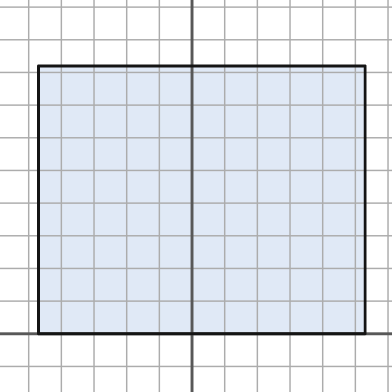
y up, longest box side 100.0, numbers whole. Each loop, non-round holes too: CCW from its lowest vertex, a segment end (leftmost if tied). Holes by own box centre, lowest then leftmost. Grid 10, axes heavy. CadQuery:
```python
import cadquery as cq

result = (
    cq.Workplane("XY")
    .moveTo(-47.0, 0.0)
    .lineTo(53.0, 0.0)
    .lineTo(53.0, 82.0)
    .lineTo(-47.0, 82.0)
    .close()
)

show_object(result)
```